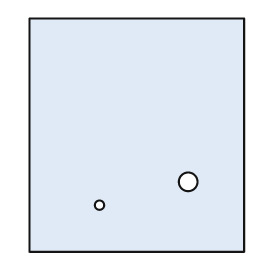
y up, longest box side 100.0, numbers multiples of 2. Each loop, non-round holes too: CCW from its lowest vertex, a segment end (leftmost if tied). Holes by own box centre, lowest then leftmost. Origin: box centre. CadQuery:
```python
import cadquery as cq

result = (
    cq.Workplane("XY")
    .moveTo(-46.0, -50.0)
    .lineTo(46.0, -50.0)
    .lineTo(46.0, 50.0)
    .lineTo(-46.0, 50.0)
    .close()
    .moveTo(-16.0, -30.0)
    .circle(2.0)
    .moveTo(22.0, -20.0)
    .circle(4.0)
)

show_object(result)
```